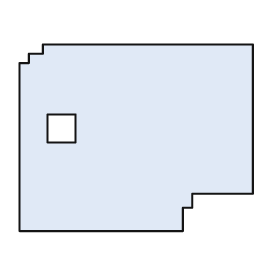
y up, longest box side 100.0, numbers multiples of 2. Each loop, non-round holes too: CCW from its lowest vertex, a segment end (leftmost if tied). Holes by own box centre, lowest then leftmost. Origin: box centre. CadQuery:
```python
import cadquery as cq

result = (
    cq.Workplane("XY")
    .moveTo(-50.0, -40.0)
    .lineTo(20.0, -40.0)
    .lineTo(20.0, -30.0)
    .lineTo(24.0, -30.0)
    .lineTo(24.0, -24.0)
    .lineTo(50.0, -24.0)
    .lineTo(50.0, 40.0)
    .lineTo(-40.0, 40.0)
    .lineTo(-40.0, 36.0)
    .lineTo(-46.0, 36.0)
    .lineTo(-46.0, 32.0)
    .lineTo(-50.0, 32.0)
    .close()
    .moveTo(-38.0, -2.0)
    .lineTo(-26.0, -2.0)
    .lineTo(-26.0, 10.0)
    .lineTo(-38.0, 10.0)
    .close()
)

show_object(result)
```